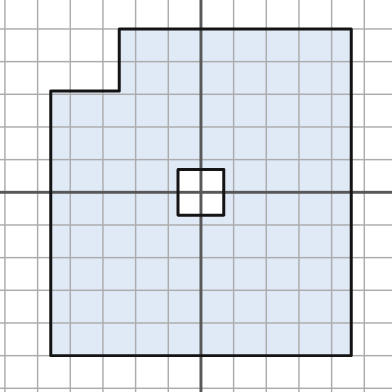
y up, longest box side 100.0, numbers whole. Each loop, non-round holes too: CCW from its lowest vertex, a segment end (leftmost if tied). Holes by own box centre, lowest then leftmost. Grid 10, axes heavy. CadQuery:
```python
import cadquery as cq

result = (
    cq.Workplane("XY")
    .moveTo(-46.0, -50.0)
    .lineTo(46.0, -50.0)
    .lineTo(46.0, 50.0)
    .lineTo(-25.0, 50.0)
    .lineTo(-25.0, 31.0)
    .lineTo(-46.0, 31.0)
    .close()
    .moveTo(-7.0, -7.0)
    .lineTo(7.0, -7.0)
    .lineTo(7.0, 7.0)
    .lineTo(-7.0, 7.0)
    .close()
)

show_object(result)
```